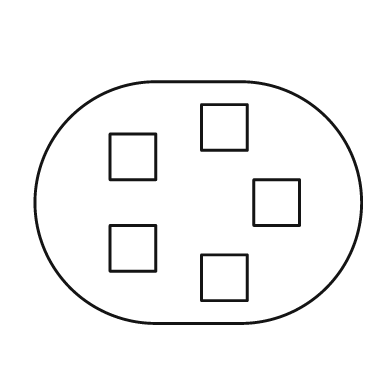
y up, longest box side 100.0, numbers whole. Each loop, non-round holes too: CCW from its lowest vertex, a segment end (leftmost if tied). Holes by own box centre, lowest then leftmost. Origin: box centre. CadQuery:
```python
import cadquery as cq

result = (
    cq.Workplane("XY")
    .moveTo(-13.0, -37.0)
    .lineTo(13.0, -37.0)
    .threePointArc((50.0, 0.0), (13.0, 37.0))
    .lineTo(-13.0, 37.0)
    .threePointArc((-50.0, 0.0), (-13.0, -37.0))
    .close()
    .moveTo(1.0, -30.0)
    .lineTo(15.0, -30.0)
    .lineTo(15.0, -16.0)
    .lineTo(1.0, -16.0)
    .close()
    .moveTo(-27.0, -21.0)
    .lineTo(-13.0, -21.0)
    .lineTo(-13.0, -7.0)
    .lineTo(-27.0, -7.0)
    .close()
    .moveTo(17.0, -7.0)
    .lineTo(31.0, -7.0)
    .lineTo(31.0, 7.0)
    .lineTo(17.0, 7.0)
    .close()
    .moveTo(-27.0, 7.0)
    .lineTo(-13.0, 7.0)
    .lineTo(-13.0, 21.0)
    .lineTo(-27.0, 21.0)
    .close()
    .moveTo(1.0, 16.0)
    .lineTo(15.0, 16.0)
    .lineTo(15.0, 30.0)
    .lineTo(1.0, 30.0)
    .close()
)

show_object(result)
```